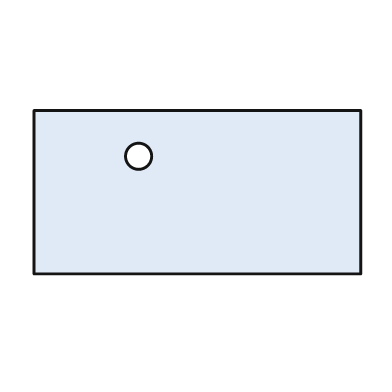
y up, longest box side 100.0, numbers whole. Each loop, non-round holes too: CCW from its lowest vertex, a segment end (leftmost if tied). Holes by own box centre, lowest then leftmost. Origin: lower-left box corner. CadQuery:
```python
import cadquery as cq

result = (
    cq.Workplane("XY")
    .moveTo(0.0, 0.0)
    .lineTo(100.0, 0.0)
    .lineTo(100.0, 50.0)
    .lineTo(0.0, 50.0)
    .close()
    .moveTo(32.0, 36.0)
    .circle(4.0)
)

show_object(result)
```